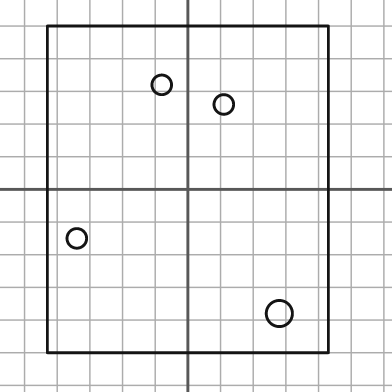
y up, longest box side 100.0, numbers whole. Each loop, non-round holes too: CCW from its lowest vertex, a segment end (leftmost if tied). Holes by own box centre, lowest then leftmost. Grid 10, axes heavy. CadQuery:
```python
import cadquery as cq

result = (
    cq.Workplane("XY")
    .moveTo(-43.0, -50.0)
    .lineTo(43.0, -50.0)
    .lineTo(43.0, 50.0)
    .lineTo(-43.0, 50.0)
    .close()
    .moveTo(28.0, -38.0)
    .circle(4.0)
    .moveTo(-34.0, -15.0)
    .circle(3.0)
    .moveTo(11.0, 26.0)
    .circle(3.0)
    .moveTo(-8.0, 32.0)
    .circle(3.0)
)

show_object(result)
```